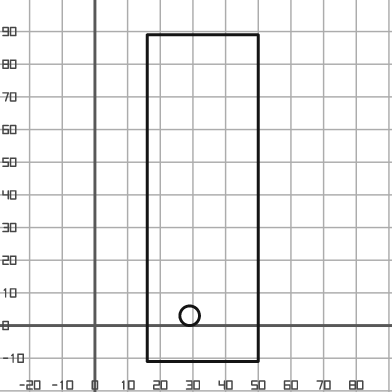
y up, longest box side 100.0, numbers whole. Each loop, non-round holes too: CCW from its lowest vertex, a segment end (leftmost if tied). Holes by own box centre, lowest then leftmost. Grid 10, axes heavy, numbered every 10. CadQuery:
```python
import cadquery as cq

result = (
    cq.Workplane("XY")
    .moveTo(16.0, -11.0)
    .lineTo(50.0, -11.0)
    .lineTo(50.0, 89.0)
    .lineTo(16.0, 89.0)
    .close()
    .moveTo(29.0, 3.0)
    .circle(3.0)
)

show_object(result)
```